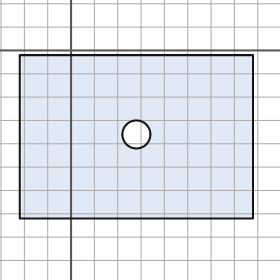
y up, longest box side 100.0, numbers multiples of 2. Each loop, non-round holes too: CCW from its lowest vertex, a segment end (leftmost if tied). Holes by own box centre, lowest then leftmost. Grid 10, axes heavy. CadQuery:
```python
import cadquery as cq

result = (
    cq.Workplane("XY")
    .moveTo(-22.0, -72.0)
    .lineTo(78.0, -72.0)
    .lineTo(78.0, -2.0)
    .lineTo(-22.0, -2.0)
    .close()
    .moveTo(28.0, -36.0)
    .circle(6.0)
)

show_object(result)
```